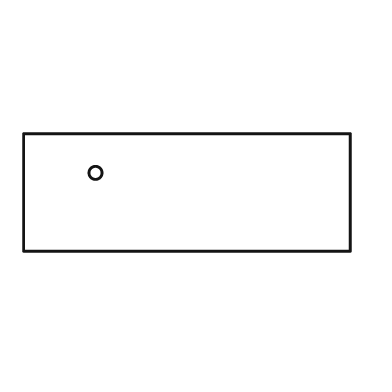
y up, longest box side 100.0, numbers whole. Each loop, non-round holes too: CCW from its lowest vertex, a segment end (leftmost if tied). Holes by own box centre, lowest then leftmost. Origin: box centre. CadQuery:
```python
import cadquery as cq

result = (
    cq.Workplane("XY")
    .moveTo(-50.0, -18.0)
    .lineTo(50.0, -18.0)
    .lineTo(50.0, 18.0)
    .lineTo(-50.0, 18.0)
    .close()
    .moveTo(-28.0, 6.0)
    .circle(2.0)
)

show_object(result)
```